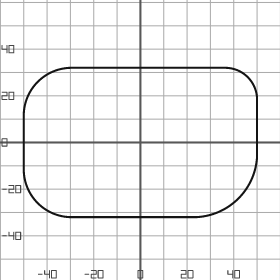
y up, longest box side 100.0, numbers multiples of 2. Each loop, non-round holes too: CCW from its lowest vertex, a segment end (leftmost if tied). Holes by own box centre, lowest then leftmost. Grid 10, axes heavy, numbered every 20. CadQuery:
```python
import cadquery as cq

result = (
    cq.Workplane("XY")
    .moveTo(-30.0, -32.0)
    .lineTo(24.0, -32.0)
    .threePointArc((42.0, -24.0), (50.0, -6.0))
    .lineTo(50.0, 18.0)
    .threePointArc((46.0, 28.0), (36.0, 32.0))
    .lineTo(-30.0, 32.0)
    .threePointArc((-44.0, 26.0), (-50.0, 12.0))
    .lineTo(-50.0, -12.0)
    .threePointArc((-44.0, -26.0), (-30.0, -32.0))
    .close()
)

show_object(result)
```